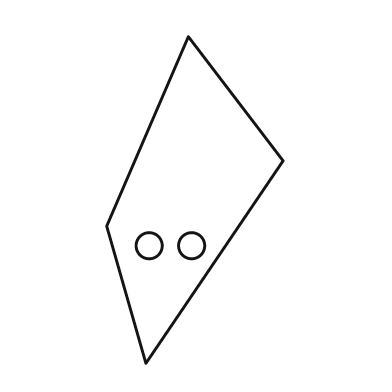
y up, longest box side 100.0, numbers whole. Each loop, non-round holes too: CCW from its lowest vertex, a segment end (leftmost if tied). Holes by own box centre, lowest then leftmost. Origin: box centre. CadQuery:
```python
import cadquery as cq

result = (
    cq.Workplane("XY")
    .moveTo(-15.0, -50.0)
    .lineTo(27.0, 12.0)
    .lineTo(-2.0, 50.0)
    .lineTo(-27.0, -8.0)
    .close()
    .moveTo(-14.0, -14.0)
    .circle(4.0)
    .moveTo(-1.0, -14.0)
    .circle(4.0)
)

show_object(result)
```